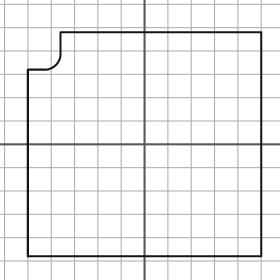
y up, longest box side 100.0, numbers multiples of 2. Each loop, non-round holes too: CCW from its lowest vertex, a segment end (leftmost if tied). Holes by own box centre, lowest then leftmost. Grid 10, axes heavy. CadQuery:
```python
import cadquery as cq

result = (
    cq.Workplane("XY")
    .moveTo(-50.0, -48.0)
    .lineTo(50.0, -48.0)
    .lineTo(50.0, 48.0)
    .lineTo(-36.0, 48.0)
    .lineTo(-36.0, 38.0)
    .threePointArc((-38.0, 34.0), (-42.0, 32.0))
    .lineTo(-50.0, 32.0)
    .close()
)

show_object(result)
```